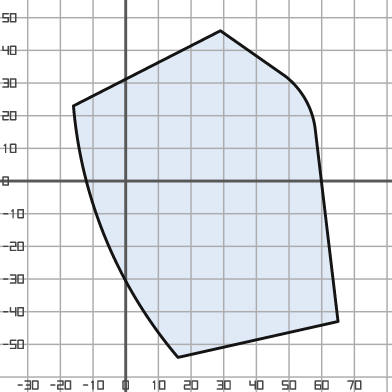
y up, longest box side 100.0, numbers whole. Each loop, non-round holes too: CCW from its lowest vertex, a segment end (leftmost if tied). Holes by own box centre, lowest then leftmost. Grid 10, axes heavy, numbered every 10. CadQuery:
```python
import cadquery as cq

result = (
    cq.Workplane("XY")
    .moveTo(16.0, -54.0)
    .lineTo(65.0, -43.0)
    .lineTo(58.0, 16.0)
    .threePointArc((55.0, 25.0), (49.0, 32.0))
    .lineTo(29.0, 46.0)
    .lineTo(-16.0, 23.0)
    .threePointArc((-6.0, -18.0), (16.0, -54.0))
    .close()
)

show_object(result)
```